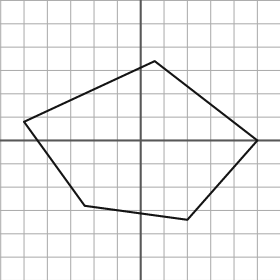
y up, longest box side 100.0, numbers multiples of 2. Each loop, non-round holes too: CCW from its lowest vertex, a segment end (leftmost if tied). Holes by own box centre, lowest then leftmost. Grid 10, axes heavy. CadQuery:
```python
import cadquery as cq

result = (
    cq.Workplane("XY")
    .moveTo(20.0, -34.0)
    .lineTo(50.0, 0.0)
    .lineTo(6.0, 34.0)
    .lineTo(-50.0, 8.0)
    .lineTo(-24.0, -28.0)
    .close()
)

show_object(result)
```